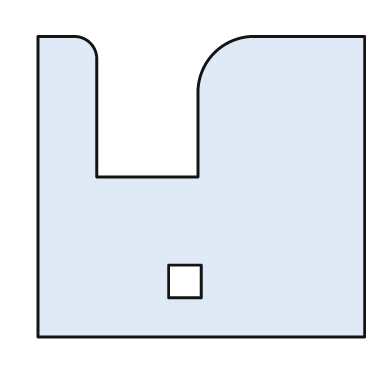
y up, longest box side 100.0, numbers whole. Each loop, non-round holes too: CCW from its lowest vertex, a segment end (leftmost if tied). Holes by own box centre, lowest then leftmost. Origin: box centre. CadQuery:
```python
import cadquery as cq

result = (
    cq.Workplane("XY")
    .moveTo(-50.0, -46.0)
    .lineTo(50.0, -46.0)
    .lineTo(50.0, 46.0)
    .lineTo(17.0, 46.0)
    .threePointArc((4.0, 41.0), (-1.0, 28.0))
    .lineTo(-1.0, 3.0)
    .lineTo(-32.0, 3.0)
    .lineTo(-32.0, 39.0)
    .threePointArc((-34.0, 44.0), (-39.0, 46.0))
    .lineTo(-50.0, 46.0)
    .close()
    .moveTo(-10.0, -34.0)
    .lineTo(0.0, -34.0)
    .lineTo(0.0, -24.0)
    .lineTo(-10.0, -24.0)
    .close()
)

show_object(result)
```